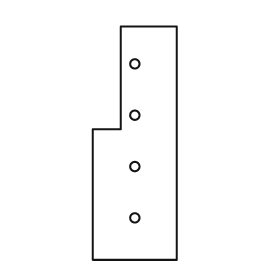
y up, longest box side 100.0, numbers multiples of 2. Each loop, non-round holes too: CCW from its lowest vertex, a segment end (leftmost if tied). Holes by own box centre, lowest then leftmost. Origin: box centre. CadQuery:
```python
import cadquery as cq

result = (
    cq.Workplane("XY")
    .moveTo(-18.0, -50.0)
    .lineTo(18.0, -50.0)
    .lineTo(18.0, 50.0)
    .lineTo(-6.0, 50.0)
    .lineTo(-6.0, 6.0)
    .lineTo(-18.0, 6.0)
    .close()
    .moveTo(0.0, -32.0)
    .circle(2.0)
    .moveTo(0.0, -10.0)
    .circle(2.0)
    .moveTo(0.0, 12.0)
    .circle(2.0)
    .moveTo(0.0, 34.0)
    .circle(2.0)
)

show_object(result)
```